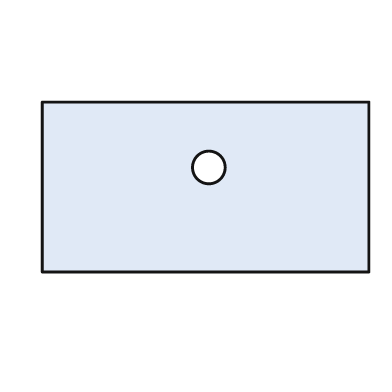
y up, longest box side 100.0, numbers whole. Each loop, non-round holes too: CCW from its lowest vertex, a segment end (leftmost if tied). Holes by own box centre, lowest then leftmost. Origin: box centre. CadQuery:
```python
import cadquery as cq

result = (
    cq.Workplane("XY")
    .moveTo(-50.0, -26.0)
    .lineTo(50.0, -26.0)
    .lineTo(50.0, 26.0)
    .lineTo(-50.0, 26.0)
    .close()
    .moveTo(1.0, 6.0)
    .circle(5.0)
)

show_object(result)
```